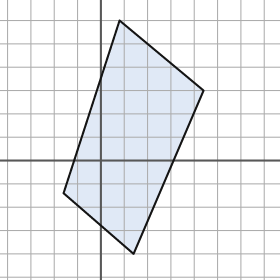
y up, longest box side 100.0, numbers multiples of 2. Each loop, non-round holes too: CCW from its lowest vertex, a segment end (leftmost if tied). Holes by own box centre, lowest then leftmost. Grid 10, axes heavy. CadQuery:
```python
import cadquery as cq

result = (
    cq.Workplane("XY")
    .moveTo(14.0, -40.0)
    .lineTo(44.0, 30.0)
    .lineTo(8.0, 60.0)
    .lineTo(-16.0, -14.0)
    .close()
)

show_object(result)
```